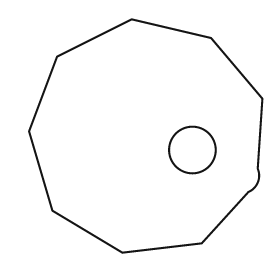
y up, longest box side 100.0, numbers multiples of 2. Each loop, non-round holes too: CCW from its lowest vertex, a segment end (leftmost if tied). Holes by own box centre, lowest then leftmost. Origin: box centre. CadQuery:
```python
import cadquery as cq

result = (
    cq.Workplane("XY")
    .moveTo(-10.0, -50.0)
    .lineTo(24.0, -46.0)
    .lineTo(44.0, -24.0)
    .threePointArc((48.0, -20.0), (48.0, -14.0))
    .lineTo(50.0, 16.0)
    .lineTo(28.0, 42.0)
    .lineTo(-6.0, 50.0)
    .lineTo(-38.0, 34.0)
    .lineTo(-50.0, 2.0)
    .lineTo(-40.0, -32.0)
    .close()
    .moveTo(20.0, -6.0)
    .circle(10.0)
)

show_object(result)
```